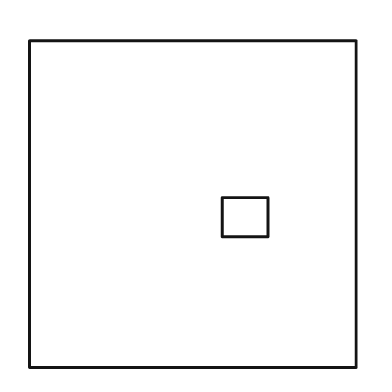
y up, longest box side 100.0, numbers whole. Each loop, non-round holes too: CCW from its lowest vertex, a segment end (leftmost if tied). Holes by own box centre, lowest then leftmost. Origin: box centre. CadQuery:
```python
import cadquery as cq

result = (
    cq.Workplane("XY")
    .moveTo(-50.0, -50.0)
    .lineTo(50.0, -50.0)
    .lineTo(50.0, 50.0)
    .lineTo(-50.0, 50.0)
    .close()
    .moveTo(9.0, -10.0)
    .lineTo(23.0, -10.0)
    .lineTo(23.0, 2.0)
    .lineTo(9.0, 2.0)
    .close()
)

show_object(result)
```